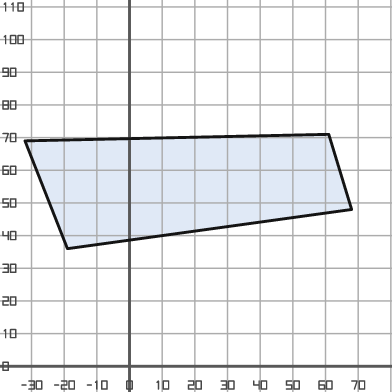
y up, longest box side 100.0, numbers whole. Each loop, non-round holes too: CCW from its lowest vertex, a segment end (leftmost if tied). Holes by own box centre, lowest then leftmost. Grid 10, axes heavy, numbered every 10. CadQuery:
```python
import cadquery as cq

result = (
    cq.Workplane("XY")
    .moveTo(-19.0, 36.0)
    .lineTo(68.0, 48.0)
    .lineTo(61.0, 71.0)
    .lineTo(-32.0, 69.0)
    .close()
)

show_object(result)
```